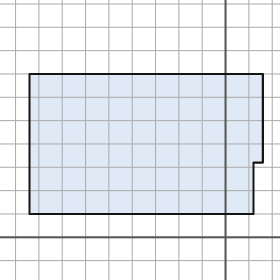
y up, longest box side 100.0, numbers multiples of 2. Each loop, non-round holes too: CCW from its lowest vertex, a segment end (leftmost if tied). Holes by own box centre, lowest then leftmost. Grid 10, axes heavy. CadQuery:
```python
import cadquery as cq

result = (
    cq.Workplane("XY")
    .moveTo(-84.0, 10.0)
    .lineTo(12.0, 10.0)
    .lineTo(12.0, 32.0)
    .lineTo(16.0, 32.0)
    .lineTo(16.0, 70.0)
    .lineTo(-84.0, 70.0)
    .close()
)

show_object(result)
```